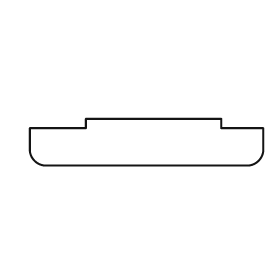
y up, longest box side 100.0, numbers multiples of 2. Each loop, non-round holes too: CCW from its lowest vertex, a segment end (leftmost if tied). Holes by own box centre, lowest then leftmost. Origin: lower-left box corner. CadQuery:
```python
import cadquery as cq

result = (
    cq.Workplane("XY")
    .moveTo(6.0, 0.0)
    .lineTo(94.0, 0.0)
    .threePointArc((98.0, 2.0), (100.0, 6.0))
    .lineTo(100.0, 16.0)
    .lineTo(82.0, 16.0)
    .lineTo(82.0, 20.0)
    .lineTo(24.0, 20.0)
    .lineTo(24.0, 16.0)
    .lineTo(0.0, 16.0)
    .lineTo(0.0, 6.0)
    .threePointArc((2.0, 2.0), (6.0, 0.0))
    .close()
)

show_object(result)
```